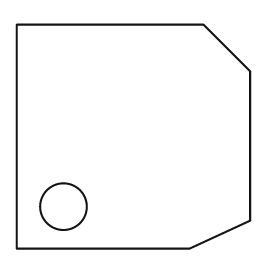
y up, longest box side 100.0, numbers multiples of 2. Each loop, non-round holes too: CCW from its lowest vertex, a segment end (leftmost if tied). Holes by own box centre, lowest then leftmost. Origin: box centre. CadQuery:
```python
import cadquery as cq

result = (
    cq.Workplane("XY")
    .moveTo(-50.0, -48.0)
    .lineTo(24.0, -48.0)
    .lineTo(50.0, -36.0)
    .lineTo(50.0, 28.0)
    .lineTo(30.0, 48.0)
    .lineTo(-50.0, 48.0)
    .close()
    .moveTo(-30.0, -30.0)
    .circle(10.0)
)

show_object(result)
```